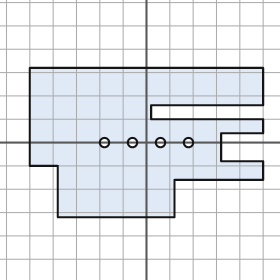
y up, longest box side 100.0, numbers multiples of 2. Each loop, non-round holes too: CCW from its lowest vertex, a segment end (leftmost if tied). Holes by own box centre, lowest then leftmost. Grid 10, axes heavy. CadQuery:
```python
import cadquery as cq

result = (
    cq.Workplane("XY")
    .moveTo(-38.0, -32.0)
    .lineTo(12.0, -32.0)
    .lineTo(12.0, -16.0)
    .lineTo(50.0, -16.0)
    .lineTo(50.0, -8.0)
    .lineTo(32.0, -8.0)
    .lineTo(32.0, 4.0)
    .lineTo(50.0, 4.0)
    .lineTo(50.0, 10.0)
    .lineTo(2.0, 10.0)
    .lineTo(2.0, 16.0)
    .lineTo(50.0, 16.0)
    .lineTo(50.0, 32.0)
    .lineTo(-50.0, 32.0)
    .lineTo(-50.0, -10.0)
    .lineTo(-38.0, -10.0)
    .close()
    .moveTo(-18.0, 0.0)
    .circle(2.0)
    .moveTo(-6.0, 0.0)
    .circle(2.0)
    .moveTo(6.0, 0.0)
    .circle(2.0)
    .moveTo(18.0, 0.0)
    .circle(2.0)
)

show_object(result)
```